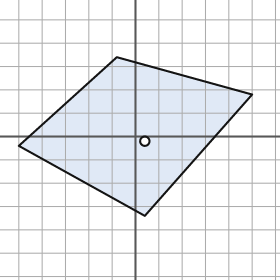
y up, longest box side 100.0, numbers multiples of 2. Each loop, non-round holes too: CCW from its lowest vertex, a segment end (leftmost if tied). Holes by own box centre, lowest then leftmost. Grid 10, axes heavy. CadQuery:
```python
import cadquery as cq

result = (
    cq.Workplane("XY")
    .moveTo(4.0, -34.0)
    .lineTo(50.0, 18.0)
    .lineTo(-8.0, 34.0)
    .lineTo(-50.0, -4.0)
    .close()
    .moveTo(4.0, -2.0)
    .circle(2.0)
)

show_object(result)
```